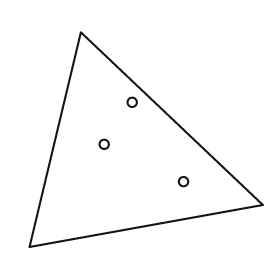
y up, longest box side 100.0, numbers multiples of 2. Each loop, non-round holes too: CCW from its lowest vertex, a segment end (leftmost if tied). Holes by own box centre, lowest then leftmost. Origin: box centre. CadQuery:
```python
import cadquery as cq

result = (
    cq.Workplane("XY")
    .moveTo(-50.0, -46.0)
    .lineTo(50.0, -28.0)
    .lineTo(-28.0, 46.0)
    .close()
    .moveTo(16.0, -18.0)
    .circle(2.0)
    .moveTo(-18.0, -2.0)
    .circle(2.0)
    .moveTo(-6.0, 16.0)
    .circle(2.0)
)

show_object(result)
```